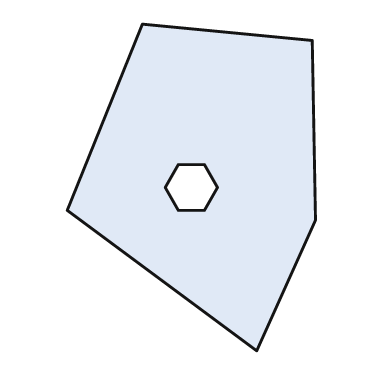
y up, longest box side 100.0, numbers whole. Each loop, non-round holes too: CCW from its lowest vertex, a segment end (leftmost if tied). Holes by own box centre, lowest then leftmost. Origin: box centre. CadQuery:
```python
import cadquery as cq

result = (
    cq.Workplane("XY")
    .moveTo(20.0, -50.0)
    .lineTo(38.0, -10.0)
    .lineTo(37.0, 45.0)
    .lineTo(-15.0, 50.0)
    .lineTo(-38.0, -7.0)
    .close()
    .moveTo(-4.0, -7.0)
    .lineTo(4.0, -7.0)
    .lineTo(8.0, 0.0)
    .lineTo(4.0, 7.0)
    .lineTo(-4.0, 7.0)
    .lineTo(-8.0, 0.0)
    .close()
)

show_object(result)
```